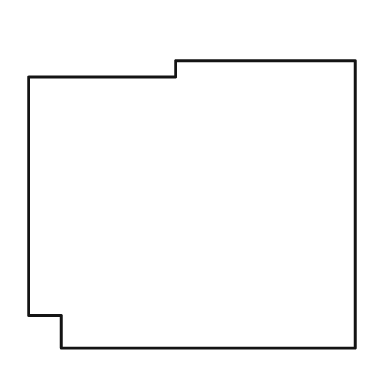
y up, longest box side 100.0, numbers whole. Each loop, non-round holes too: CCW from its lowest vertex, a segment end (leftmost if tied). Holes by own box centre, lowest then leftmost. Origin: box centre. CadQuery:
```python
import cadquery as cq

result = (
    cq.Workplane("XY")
    .moveTo(-40.0, -44.0)
    .lineTo(50.0, -44.0)
    .lineTo(50.0, 44.0)
    .lineTo(-5.0, 44.0)
    .lineTo(-5.0, 39.0)
    .lineTo(-50.0, 39.0)
    .lineTo(-50.0, -34.0)
    .lineTo(-40.0, -34.0)
    .close()
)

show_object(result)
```